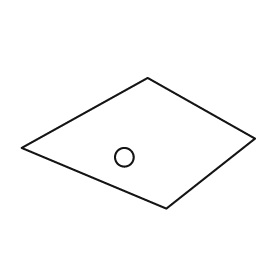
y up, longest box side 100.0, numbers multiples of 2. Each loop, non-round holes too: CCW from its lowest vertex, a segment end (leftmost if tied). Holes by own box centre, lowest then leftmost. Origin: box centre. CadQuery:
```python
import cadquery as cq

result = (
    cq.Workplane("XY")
    .moveTo(12.0, -28.0)
    .lineTo(50.0, 2.0)
    .lineTo(4.0, 28.0)
    .lineTo(-50.0, -2.0)
    .close()
    .moveTo(-6.0, -6.0)
    .circle(4.0)
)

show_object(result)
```